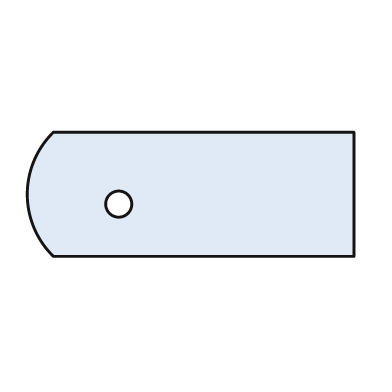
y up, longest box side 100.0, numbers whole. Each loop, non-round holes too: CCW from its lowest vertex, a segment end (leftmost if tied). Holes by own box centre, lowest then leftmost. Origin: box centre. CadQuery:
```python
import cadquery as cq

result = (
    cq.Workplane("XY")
    .moveTo(-42.0, -19.0)
    .lineTo(50.0, -19.0)
    .lineTo(50.0, 19.0)
    .lineTo(-42.0, 19.0)
    .threePointArc((-50.0, 0.0), (-42.0, -19.0))
    .close()
    .moveTo(-22.0, -3.0)
    .circle(4.0)
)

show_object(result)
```